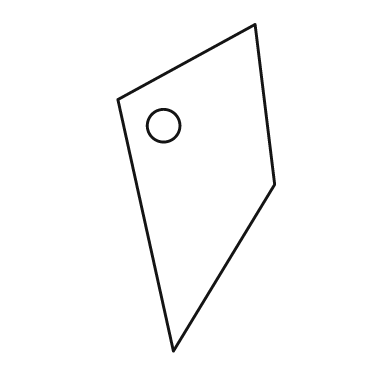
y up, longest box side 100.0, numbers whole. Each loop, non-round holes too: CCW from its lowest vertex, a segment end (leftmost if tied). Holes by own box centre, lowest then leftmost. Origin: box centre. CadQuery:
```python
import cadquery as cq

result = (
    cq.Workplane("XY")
    .moveTo(-7.0, -50.0)
    .lineTo(24.0, 1.0)
    .lineTo(18.0, 50.0)
    .lineTo(-24.0, 27.0)
    .close()
    .moveTo(-10.0, 19.0)
    .circle(5.0)
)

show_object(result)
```